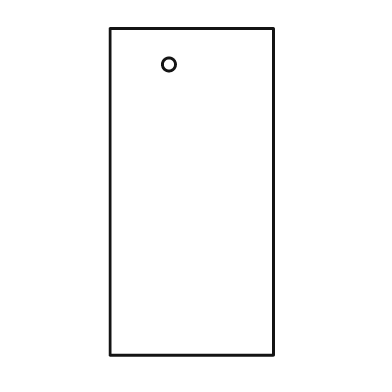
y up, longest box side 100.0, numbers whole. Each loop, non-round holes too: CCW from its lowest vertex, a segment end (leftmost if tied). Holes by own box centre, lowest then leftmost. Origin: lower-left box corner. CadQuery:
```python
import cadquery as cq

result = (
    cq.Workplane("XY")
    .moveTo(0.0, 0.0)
    .lineTo(50.0, 0.0)
    .lineTo(50.0, 100.0)
    .lineTo(0.0, 100.0)
    .close()
    .moveTo(18.0, 89.0)
    .circle(2.0)
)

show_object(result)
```